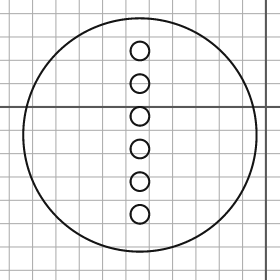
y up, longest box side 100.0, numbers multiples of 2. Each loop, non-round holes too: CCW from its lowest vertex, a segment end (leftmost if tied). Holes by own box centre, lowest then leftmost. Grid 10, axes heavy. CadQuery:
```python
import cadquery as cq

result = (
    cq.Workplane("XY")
    .moveTo(-54.0, -12.0)
    .circle(50.0)
    .moveTo(-54.0, -46.0)
    .circle(4.0)
    .moveTo(-54.0, -32.0)
    .circle(4.0)
    .moveTo(-54.0, -18.0)
    .circle(4.0)
    .moveTo(-54.0, -4.0)
    .circle(4.0)
    .moveTo(-54.0, 10.0)
    .circle(4.0)
    .moveTo(-54.0, 24.0)
    .circle(4.0)
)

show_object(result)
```